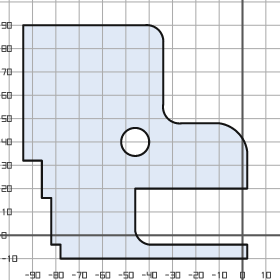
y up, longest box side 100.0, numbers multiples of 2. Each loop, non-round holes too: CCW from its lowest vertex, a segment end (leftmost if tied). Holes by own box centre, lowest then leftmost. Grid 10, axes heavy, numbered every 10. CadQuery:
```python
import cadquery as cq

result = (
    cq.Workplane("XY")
    .moveTo(-78.0, -10.0)
    .lineTo(2.0, -10.0)
    .lineTo(2.0, -4.0)
    .lineTo(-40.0, -4.0)
    .threePointArc((-44.0, -2.0), (-46.0, 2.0))
    .lineTo(-46.0, 20.0)
    .lineTo(2.0, 20.0)
    .lineTo(2.0, 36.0)
    .threePointArc((-2.0, 44.0), (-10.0, 48.0))
    .lineTo(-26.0, 48.0)
    .threePointArc((-32.0, 50.0), (-34.0, 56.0))
    .lineTo(-34.0, 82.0)
    .threePointArc((-36.0, 88.0), (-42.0, 90.0))
    .lineTo(-94.0, 90.0)
    .lineTo(-94.0, 32.0)
    .lineTo(-86.0, 32.0)
    .lineTo(-86.0, 16.0)
    .lineTo(-82.0, 16.0)
    .lineTo(-82.0, -4.0)
    .lineTo(-78.0, -4.0)
    .close()
    .moveTo(-46.0, 40.0)
    .circle(6.0)
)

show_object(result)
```